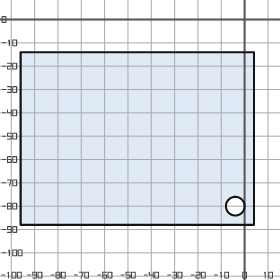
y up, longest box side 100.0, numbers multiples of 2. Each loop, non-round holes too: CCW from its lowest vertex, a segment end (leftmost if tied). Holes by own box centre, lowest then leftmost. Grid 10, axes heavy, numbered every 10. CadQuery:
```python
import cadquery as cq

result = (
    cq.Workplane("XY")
    .moveTo(-96.0, -88.0)
    .lineTo(4.0, -88.0)
    .lineTo(4.0, -14.0)
    .lineTo(-96.0, -14.0)
    .close()
    .moveTo(-4.0, -80.0)
    .circle(4.0)
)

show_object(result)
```